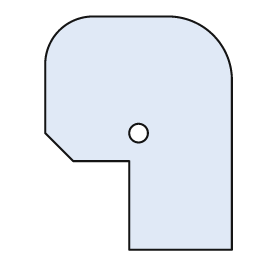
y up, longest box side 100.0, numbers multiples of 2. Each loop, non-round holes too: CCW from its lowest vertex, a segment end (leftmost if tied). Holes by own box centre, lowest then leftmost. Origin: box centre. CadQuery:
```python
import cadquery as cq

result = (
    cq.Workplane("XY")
    .moveTo(-4.0, -50.0)
    .lineTo(40.0, -50.0)
    .lineTo(40.0, 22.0)
    .threePointArc((32.0, 42.0), (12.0, 50.0))
    .lineTo(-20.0, 50.0)
    .threePointArc((-34.0, 44.0), (-40.0, 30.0))
    .lineTo(-40.0, 0.0)
    .lineTo(-28.0, -12.0)
    .lineTo(-4.0, -12.0)
    .close()
    .moveTo(0.0, 0.0)
    .circle(4.0)
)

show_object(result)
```